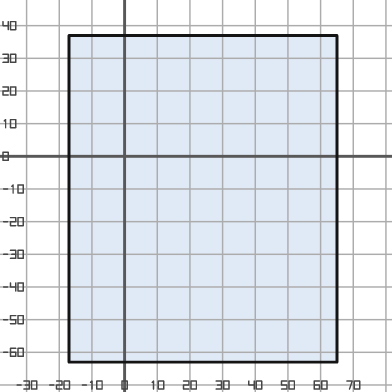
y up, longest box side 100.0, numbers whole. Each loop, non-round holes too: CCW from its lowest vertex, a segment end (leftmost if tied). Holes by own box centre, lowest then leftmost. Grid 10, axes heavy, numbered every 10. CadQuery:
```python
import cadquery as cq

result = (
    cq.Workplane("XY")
    .moveTo(-17.0, -63.0)
    .lineTo(65.0, -63.0)
    .lineTo(65.0, 37.0)
    .lineTo(-17.0, 37.0)
    .close()
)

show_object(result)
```